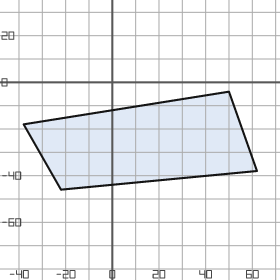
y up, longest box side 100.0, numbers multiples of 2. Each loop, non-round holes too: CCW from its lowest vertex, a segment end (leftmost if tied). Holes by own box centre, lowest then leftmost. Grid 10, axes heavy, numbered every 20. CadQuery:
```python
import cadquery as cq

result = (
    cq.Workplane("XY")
    .moveTo(-22.0, -46.0)
    .lineTo(62.0, -38.0)
    .lineTo(50.0, -4.0)
    .lineTo(-38.0, -18.0)
    .close()
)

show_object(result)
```